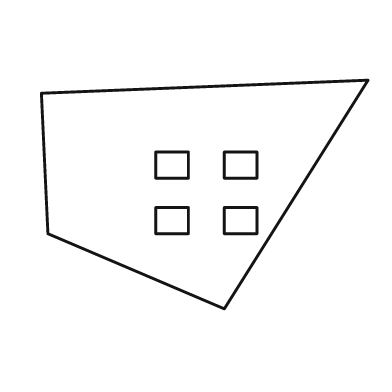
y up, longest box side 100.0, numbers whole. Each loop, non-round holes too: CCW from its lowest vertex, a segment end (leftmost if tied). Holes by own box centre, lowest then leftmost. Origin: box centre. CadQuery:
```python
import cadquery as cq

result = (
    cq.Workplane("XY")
    .moveTo(6.0, -35.0)
    .lineTo(50.0, 35.0)
    .lineTo(-50.0, 31.0)
    .lineTo(-48.0, -12.0)
    .close()
    .moveTo(-15.0, -12.0)
    .lineTo(-5.0, -12.0)
    .lineTo(-5.0, -4.0)
    .lineTo(-15.0, -4.0)
    .close()
    .moveTo(6.0, -12.0)
    .lineTo(16.0, -12.0)
    .lineTo(16.0, -4.0)
    .lineTo(6.0, -4.0)
    .close()
    .moveTo(-15.0, 5.0)
    .lineTo(-5.0, 5.0)
    .lineTo(-5.0, 13.0)
    .lineTo(-15.0, 13.0)
    .close()
    .moveTo(6.0, 5.0)
    .lineTo(16.0, 5.0)
    .lineTo(16.0, 13.0)
    .lineTo(6.0, 13.0)
    .close()
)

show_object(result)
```